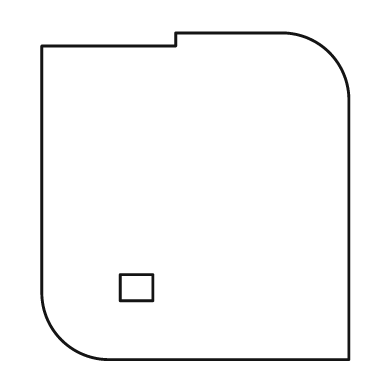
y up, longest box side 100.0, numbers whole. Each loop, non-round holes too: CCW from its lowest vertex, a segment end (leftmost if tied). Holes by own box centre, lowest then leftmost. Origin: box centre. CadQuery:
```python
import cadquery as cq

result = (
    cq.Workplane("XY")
    .moveTo(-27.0, -50.0)
    .lineTo(47.0, -50.0)
    .lineTo(47.0, 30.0)
    .threePointArc((41.0, 44.0), (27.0, 50.0))
    .lineTo(-6.0, 50.0)
    .lineTo(-6.0, 46.0)
    .lineTo(-47.0, 46.0)
    .lineTo(-47.0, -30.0)
    .threePointArc((-41.0, -44.0), (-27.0, -50.0))
    .close()
    .moveTo(-23.0, -32.0)
    .lineTo(-13.0, -32.0)
    .lineTo(-13.0, -24.0)
    .lineTo(-23.0, -24.0)
    .close()
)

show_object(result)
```